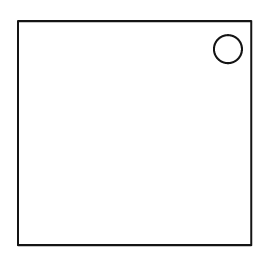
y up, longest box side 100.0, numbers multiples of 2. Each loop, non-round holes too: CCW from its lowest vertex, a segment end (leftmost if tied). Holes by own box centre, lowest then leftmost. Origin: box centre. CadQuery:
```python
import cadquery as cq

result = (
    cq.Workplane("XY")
    .moveTo(-50.0, -48.0)
    .lineTo(50.0, -48.0)
    .lineTo(50.0, 48.0)
    .lineTo(-50.0, 48.0)
    .close()
    .moveTo(40.0, 36.0)
    .circle(6.0)
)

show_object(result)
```